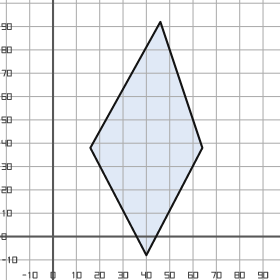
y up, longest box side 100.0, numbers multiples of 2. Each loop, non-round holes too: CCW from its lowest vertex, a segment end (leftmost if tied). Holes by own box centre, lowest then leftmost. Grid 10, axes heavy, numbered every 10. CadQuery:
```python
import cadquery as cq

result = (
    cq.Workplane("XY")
    .moveTo(40.0, -8.0)
    .lineTo(64.0, 38.0)
    .lineTo(46.0, 92.0)
    .lineTo(16.0, 38.0)
    .close()
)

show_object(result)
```